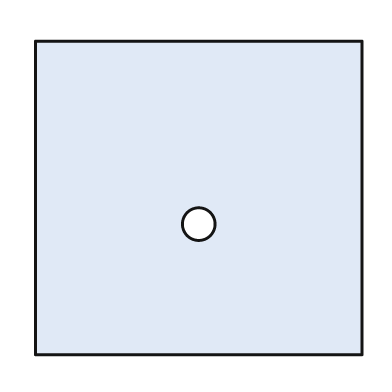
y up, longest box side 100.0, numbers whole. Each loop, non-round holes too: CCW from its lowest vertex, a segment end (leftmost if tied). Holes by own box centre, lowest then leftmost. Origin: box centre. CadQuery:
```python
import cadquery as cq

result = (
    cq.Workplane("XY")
    .moveTo(-50.0, -48.0)
    .lineTo(50.0, -48.0)
    .lineTo(50.0, 48.0)
    .lineTo(-50.0, 48.0)
    .close()
    .moveTo(0.0, -8.0)
    .circle(5.0)
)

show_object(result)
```